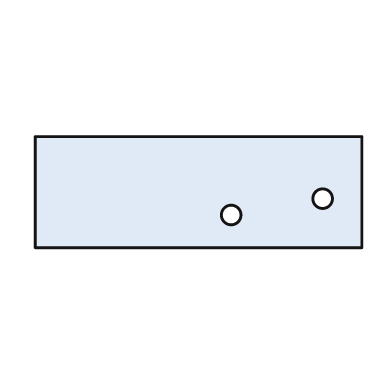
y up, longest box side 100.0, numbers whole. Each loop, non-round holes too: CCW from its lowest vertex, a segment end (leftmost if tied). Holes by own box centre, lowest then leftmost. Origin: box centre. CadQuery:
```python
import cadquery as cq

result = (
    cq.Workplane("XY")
    .moveTo(-50.0, -17.0)
    .lineTo(50.0, -17.0)
    .lineTo(50.0, 17.0)
    .lineTo(-50.0, 17.0)
    .close()
    .moveTo(10.0, -7.0)
    .circle(3.0)
    .moveTo(38.0, -2.0)
    .circle(3.0)
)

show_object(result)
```